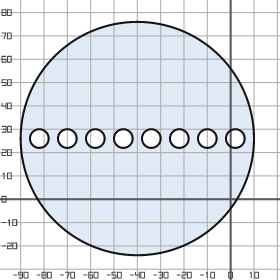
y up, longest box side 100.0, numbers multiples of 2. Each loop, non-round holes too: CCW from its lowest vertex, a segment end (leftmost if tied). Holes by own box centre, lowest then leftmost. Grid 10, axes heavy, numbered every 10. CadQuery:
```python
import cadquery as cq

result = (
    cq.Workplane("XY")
    .moveTo(-40.0, 26.0)
    .circle(50.0)
    .moveTo(-82.0, 26.0)
    .circle(4.0)
    .moveTo(-70.0, 26.0)
    .circle(4.0)
    .moveTo(-58.0, 26.0)
    .circle(4.0)
    .moveTo(-46.0, 26.0)
    .circle(4.0)
    .moveTo(-34.0, 26.0)
    .circle(4.0)
    .moveTo(-22.0, 26.0)
    .circle(4.0)
    .moveTo(-10.0, 26.0)
    .circle(4.0)
    .moveTo(2.0, 26.0)
    .circle(4.0)
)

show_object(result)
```